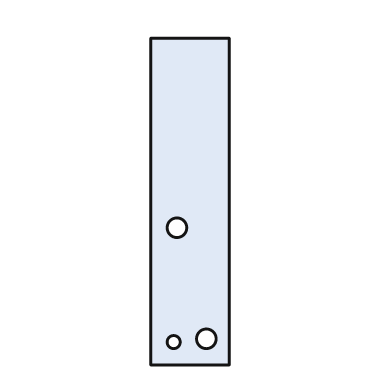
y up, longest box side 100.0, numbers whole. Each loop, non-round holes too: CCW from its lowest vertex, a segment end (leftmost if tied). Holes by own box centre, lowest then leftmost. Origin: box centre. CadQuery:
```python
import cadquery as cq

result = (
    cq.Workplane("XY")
    .moveTo(-12.0, -50.0)
    .lineTo(12.0, -50.0)
    .lineTo(12.0, 50.0)
    .lineTo(-12.0, 50.0)
    .close()
    .moveTo(-5.0, -43.0)
    .circle(2.0)
    .moveTo(5.0, -42.0)
    .circle(3.0)
    .moveTo(-4.0, -8.0)
    .circle(3.0)
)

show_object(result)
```